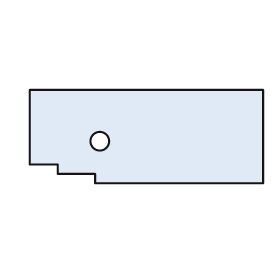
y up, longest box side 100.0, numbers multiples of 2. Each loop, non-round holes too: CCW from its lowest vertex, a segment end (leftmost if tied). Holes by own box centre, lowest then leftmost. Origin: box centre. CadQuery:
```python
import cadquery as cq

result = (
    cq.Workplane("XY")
    .moveTo(-22.0, -20.0)
    .lineTo(50.0, -20.0)
    .lineTo(50.0, 20.0)
    .lineTo(-50.0, 20.0)
    .lineTo(-50.0, -12.0)
    .lineTo(-38.0, -12.0)
    .lineTo(-38.0, -16.0)
    .lineTo(-22.0, -16.0)
    .close()
    .moveTo(-20.0, -2.0)
    .circle(4.0)
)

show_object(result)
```